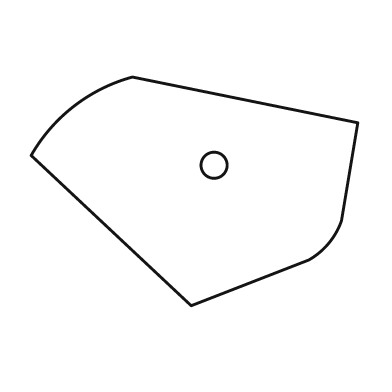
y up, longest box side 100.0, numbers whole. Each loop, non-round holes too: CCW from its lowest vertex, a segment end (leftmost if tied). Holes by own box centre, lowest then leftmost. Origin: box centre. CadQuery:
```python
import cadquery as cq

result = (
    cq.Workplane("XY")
    .moveTo(-1.0, -35.0)
    .lineTo(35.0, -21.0)
    .threePointArc((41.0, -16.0), (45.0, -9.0))
    .lineTo(50.0, 21.0)
    .lineTo(-19.0, 35.0)
    .threePointArc((-37.0, 26.0), (-50.0, 11.0))
    .close()
    .moveTo(6.0, 8.0)
    .circle(4.0)
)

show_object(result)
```